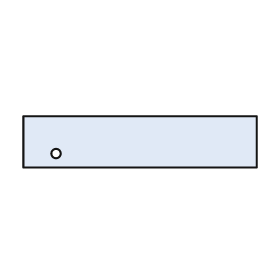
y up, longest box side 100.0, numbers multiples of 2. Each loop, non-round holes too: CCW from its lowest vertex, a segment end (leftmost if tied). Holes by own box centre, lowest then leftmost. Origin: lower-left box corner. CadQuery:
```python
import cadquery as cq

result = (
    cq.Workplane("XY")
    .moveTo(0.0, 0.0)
    .lineTo(100.0, 0.0)
    .lineTo(100.0, 22.0)
    .lineTo(0.0, 22.0)
    .close()
    .moveTo(14.0, 6.0)
    .circle(2.0)
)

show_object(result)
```